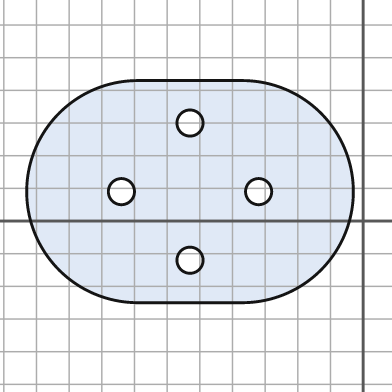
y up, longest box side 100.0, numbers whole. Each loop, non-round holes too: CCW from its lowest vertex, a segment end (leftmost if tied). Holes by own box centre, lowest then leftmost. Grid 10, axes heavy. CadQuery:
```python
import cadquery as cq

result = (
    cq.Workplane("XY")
    .moveTo(-69.0, -25.0)
    .lineTo(-37.0, -25.0)
    .threePointArc((-3.0, 9.0), (-37.0, 43.0))
    .lineTo(-69.0, 43.0)
    .threePointArc((-103.0, 9.0), (-69.0, -25.0))
    .close()
    .moveTo(-53.0, -12.0)
    .circle(4.0)
    .moveTo(-74.0, 9.0)
    .circle(4.0)
    .moveTo(-32.0, 9.0)
    .circle(4.0)
    .moveTo(-53.0, 30.0)
    .circle(4.0)
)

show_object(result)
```